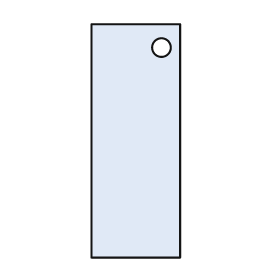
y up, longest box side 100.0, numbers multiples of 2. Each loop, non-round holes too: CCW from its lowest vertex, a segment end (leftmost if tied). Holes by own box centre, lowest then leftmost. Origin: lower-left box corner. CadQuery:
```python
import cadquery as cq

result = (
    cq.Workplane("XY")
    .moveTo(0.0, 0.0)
    .lineTo(38.0, 0.0)
    .lineTo(38.0, 100.0)
    .lineTo(0.0, 100.0)
    .close()
    .moveTo(30.0, 90.0)
    .circle(4.0)
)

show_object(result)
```